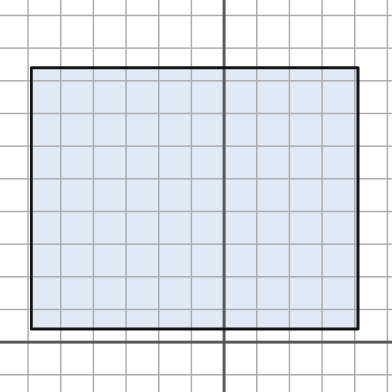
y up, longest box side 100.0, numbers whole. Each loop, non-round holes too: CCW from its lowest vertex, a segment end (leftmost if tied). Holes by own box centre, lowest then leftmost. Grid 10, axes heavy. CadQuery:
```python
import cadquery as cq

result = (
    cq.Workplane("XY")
    .moveTo(-59.0, 4.0)
    .lineTo(41.0, 4.0)
    .lineTo(41.0, 84.0)
    .lineTo(-59.0, 84.0)
    .close()
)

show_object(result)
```